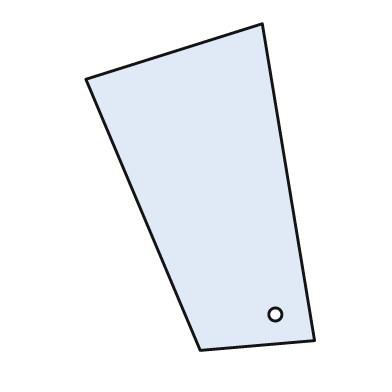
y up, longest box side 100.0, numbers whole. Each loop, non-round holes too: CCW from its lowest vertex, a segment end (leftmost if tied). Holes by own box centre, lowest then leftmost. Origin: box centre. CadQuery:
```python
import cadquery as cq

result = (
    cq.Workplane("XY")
    .moveTo(0.0, -50.0)
    .lineTo(35.0, -47.0)
    .lineTo(19.0, 50.0)
    .lineTo(-35.0, 33.0)
    .close()
    .moveTo(23.0, -39.0)
    .circle(2.0)
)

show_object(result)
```